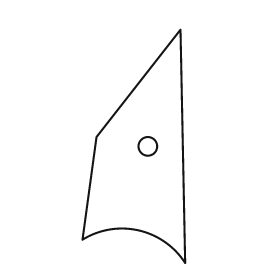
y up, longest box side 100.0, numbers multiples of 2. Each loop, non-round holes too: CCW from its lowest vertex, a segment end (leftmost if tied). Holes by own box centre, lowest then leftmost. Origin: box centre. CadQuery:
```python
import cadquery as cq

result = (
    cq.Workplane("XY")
    .moveTo(22.0, -50.0)
    .lineTo(20.0, 50.0)
    .lineTo(-16.0, 4.0)
    .lineTo(-22.0, -40.0)
    .threePointArc((2.0, -36.0), (22.0, -50.0))
    .close()
    .moveTo(6.0, 0.0)
    .circle(4.0)
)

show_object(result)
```